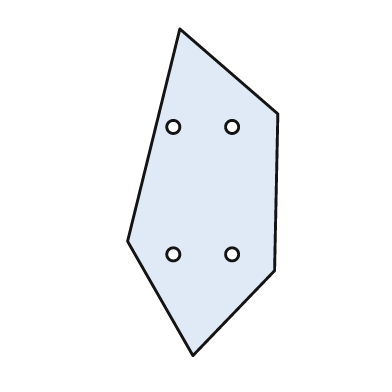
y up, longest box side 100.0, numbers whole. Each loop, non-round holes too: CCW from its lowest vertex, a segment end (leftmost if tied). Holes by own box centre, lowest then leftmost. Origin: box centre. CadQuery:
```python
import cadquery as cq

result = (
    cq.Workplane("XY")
    .moveTo(-3.0, -50.0)
    .lineTo(22.0, -24.0)
    .lineTo(23.0, 24.0)
    .lineTo(-7.0, 50.0)
    .lineTo(-23.0, -15.0)
    .close()
    .moveTo(-9.0, -19.0)
    .circle(2.0)
    .moveTo(9.0, -19.0)
    .circle(2.0)
    .moveTo(-9.0, 20.0)
    .circle(2.0)
    .moveTo(9.0, 20.0)
    .circle(2.0)
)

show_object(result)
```